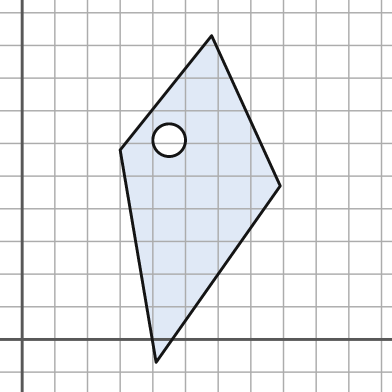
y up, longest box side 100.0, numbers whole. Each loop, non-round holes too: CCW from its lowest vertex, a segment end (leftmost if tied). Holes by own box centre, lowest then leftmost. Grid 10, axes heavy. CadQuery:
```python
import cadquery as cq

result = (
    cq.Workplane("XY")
    .moveTo(41.0, -7.0)
    .lineTo(79.0, 47.0)
    .lineTo(58.0, 93.0)
    .lineTo(30.0, 58.0)
    .close()
    .moveTo(45.0, 61.0)
    .circle(5.0)
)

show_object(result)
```